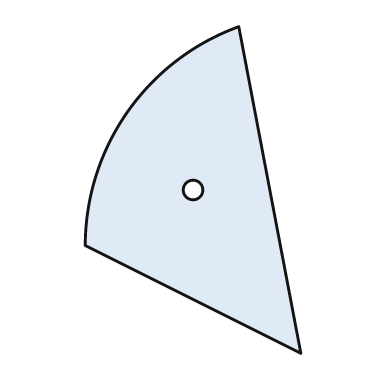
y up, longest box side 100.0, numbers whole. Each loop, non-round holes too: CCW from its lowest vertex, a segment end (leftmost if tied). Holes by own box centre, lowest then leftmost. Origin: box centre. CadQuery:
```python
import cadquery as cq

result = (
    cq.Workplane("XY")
    .moveTo(33.0, -50.0)
    .lineTo(14.0, 50.0)
    .threePointArc((-20.0, 24.0), (-33.0, -17.0))
    .close()
    .moveTo(0.0, 0.0)
    .circle(3.0)
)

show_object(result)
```